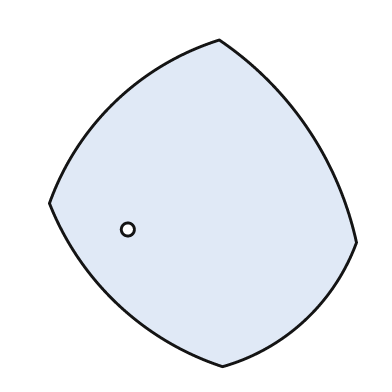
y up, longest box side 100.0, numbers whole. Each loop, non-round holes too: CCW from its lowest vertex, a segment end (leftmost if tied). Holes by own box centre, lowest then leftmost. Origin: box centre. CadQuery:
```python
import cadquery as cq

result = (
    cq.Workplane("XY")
    .moveTo(6.0, -50.0)
    .threePointArc((31.0, -36.0), (47.0, -12.0))
    .threePointArc((32.0, 23.0), (5.0, 50.0))
    .threePointArc((-27.0, 31.0), (-47.0, 0.0))
    .threePointArc((-26.0, -31.0), (6.0, -50.0))
    .close()
    .moveTo(-23.0, -8.0)
    .circle(2.0)
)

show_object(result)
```